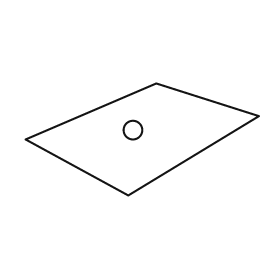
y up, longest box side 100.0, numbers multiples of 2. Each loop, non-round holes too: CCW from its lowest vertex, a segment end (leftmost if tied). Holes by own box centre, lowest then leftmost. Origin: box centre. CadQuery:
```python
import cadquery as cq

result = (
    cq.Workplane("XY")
    .moveTo(-6.0, -24.0)
    .lineTo(50.0, 10.0)
    .lineTo(6.0, 24.0)
    .lineTo(-50.0, 0.0)
    .close()
    .moveTo(-4.0, 4.0)
    .circle(4.0)
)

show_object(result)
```